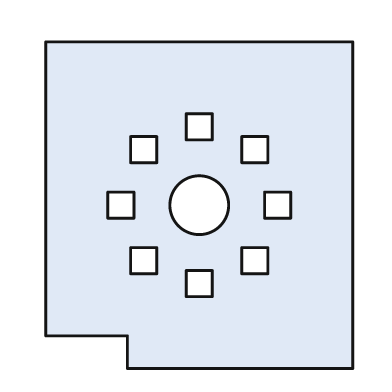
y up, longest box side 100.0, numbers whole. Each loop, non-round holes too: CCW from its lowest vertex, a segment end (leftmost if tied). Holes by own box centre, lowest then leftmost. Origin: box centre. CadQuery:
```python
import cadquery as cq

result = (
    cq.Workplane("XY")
    .moveTo(-22.0, -50.0)
    .lineTo(47.0, -50.0)
    .lineTo(47.0, 50.0)
    .lineTo(-47.0, 50.0)
    .lineTo(-47.0, -40.0)
    .lineTo(-22.0, -40.0)
    .close()
    .moveTo(-4.0, -28.0)
    .lineTo(4.0, -28.0)
    .lineTo(4.0, -20.0)
    .lineTo(-4.0, -20.0)
    .close()
    .moveTo(-21.0, -21.0)
    .lineTo(-13.0, -21.0)
    .lineTo(-13.0, -13.0)
    .lineTo(-21.0, -13.0)
    .close()
    .moveTo(13.0, -21.0)
    .lineTo(21.0, -21.0)
    .lineTo(21.0, -13.0)
    .lineTo(13.0, -13.0)
    .close()
    .moveTo(-28.0, -4.0)
    .lineTo(-20.0, -4.0)
    .lineTo(-20.0, 4.0)
    .lineTo(-28.0, 4.0)
    .close()
    .moveTo(0.0, 0.0)
    .circle(9.0)
    .moveTo(20.0, -4.0)
    .lineTo(28.0, -4.0)
    .lineTo(28.0, 4.0)
    .lineTo(20.0, 4.0)
    .close()
    .moveTo(-21.0, 13.0)
    .lineTo(-13.0, 13.0)
    .lineTo(-13.0, 21.0)
    .lineTo(-21.0, 21.0)
    .close()
    .moveTo(13.0, 13.0)
    .lineTo(21.0, 13.0)
    .lineTo(21.0, 21.0)
    .lineTo(13.0, 21.0)
    .close()
    .moveTo(-4.0, 20.0)
    .lineTo(4.0, 20.0)
    .lineTo(4.0, 28.0)
    .lineTo(-4.0, 28.0)
    .close()
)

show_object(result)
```